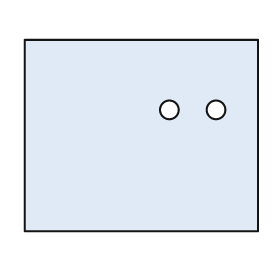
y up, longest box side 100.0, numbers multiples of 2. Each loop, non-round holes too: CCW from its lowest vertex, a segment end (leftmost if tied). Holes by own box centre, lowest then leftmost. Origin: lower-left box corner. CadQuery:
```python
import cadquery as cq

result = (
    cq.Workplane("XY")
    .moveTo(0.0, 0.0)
    .lineTo(100.0, 0.0)
    .lineTo(100.0, 82.0)
    .lineTo(0.0, 82.0)
    .close()
    .moveTo(62.0, 52.0)
    .circle(4.0)
    .moveTo(82.0, 52.0)
    .circle(4.0)
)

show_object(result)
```